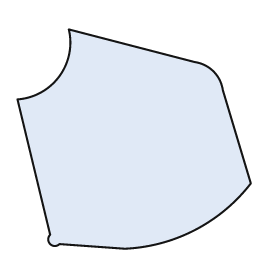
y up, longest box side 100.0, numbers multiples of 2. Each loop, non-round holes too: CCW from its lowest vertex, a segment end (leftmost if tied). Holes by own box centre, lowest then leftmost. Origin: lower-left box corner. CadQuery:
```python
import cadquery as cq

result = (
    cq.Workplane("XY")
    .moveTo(46.0, 0.0)
    .threePointArc((76.0, 8.0), (100.0, 28.0))
    .lineTo(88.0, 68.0)
    .threePointArc((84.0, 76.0), (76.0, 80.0))
    .lineTo(22.0, 94.0)
    .threePointArc((18.0, 74.0), (0.0, 64.0))
    .lineTo(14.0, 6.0)
    .threePointArc((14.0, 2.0), (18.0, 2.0))
    .close()
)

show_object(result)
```